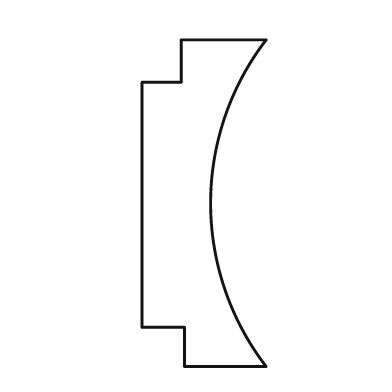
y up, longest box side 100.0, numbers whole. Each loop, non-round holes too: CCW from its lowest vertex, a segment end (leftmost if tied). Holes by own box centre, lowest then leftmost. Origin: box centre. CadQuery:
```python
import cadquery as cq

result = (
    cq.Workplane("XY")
    .moveTo(-6.0, -50.0)
    .lineTo(19.0, -50.0)
    .threePointArc((2.0, 0.0), (19.0, 50.0))
    .lineTo(-7.0, 50.0)
    .lineTo(-7.0, 37.0)
    .lineTo(-19.0, 37.0)
    .lineTo(-19.0, -38.0)
    .lineTo(-6.0, -38.0)
    .close()
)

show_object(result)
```